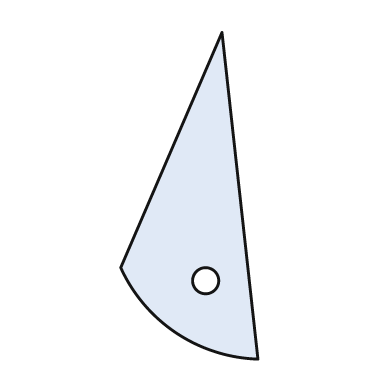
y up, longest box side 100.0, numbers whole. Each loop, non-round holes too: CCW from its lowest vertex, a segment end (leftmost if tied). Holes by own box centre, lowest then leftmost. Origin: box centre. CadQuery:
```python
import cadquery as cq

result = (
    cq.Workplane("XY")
    .moveTo(21.0, -50.0)
    .lineTo(10.0, 50.0)
    .lineTo(-21.0, -22.0)
    .threePointArc((-4.0, -42.0), (21.0, -50.0))
    .close()
    .moveTo(5.0, -26.0)
    .circle(4.0)
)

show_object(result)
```